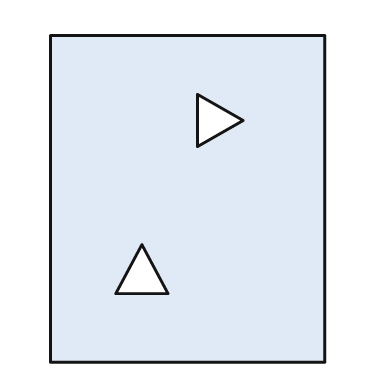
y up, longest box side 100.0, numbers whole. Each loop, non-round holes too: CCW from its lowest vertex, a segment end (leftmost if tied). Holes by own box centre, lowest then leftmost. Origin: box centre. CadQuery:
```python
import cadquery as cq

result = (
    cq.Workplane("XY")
    .moveTo(-42.0, -50.0)
    .lineTo(42.0, -50.0)
    .lineTo(42.0, 50.0)
    .lineTo(-42.0, 50.0)
    .close()
    .moveTo(-22.0, -29.0)
    .lineTo(-6.0, -29.0)
    .lineTo(-14.0, -14.0)
    .close()
    .moveTo(3.0, 16.0)
    .lineTo(17.0, 24.0)
    .lineTo(3.0, 32.0)
    .close()
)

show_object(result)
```